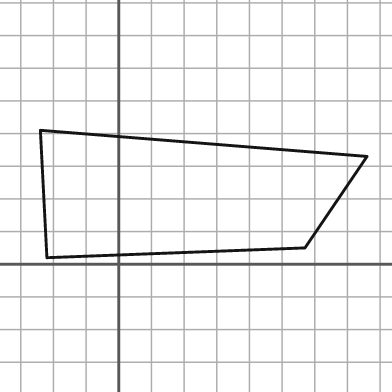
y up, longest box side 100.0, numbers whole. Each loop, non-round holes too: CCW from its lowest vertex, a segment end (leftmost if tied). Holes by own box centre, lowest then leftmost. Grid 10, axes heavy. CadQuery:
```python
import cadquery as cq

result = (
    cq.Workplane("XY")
    .moveTo(-22.0, 2.0)
    .lineTo(57.0, 5.0)
    .lineTo(76.0, 33.0)
    .lineTo(-24.0, 41.0)
    .close()
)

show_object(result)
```